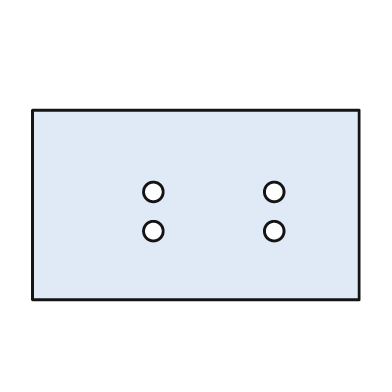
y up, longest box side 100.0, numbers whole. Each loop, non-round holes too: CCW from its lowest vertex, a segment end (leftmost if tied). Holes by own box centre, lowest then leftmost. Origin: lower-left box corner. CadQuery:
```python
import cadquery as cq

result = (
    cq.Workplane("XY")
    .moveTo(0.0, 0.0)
    .lineTo(100.0, 0.0)
    .lineTo(100.0, 58.0)
    .lineTo(0.0, 58.0)
    .close()
    .moveTo(37.0, 21.0)
    .circle(3.0)
    .moveTo(74.0, 21.0)
    .circle(3.0)
    .moveTo(37.0, 33.0)
    .circle(3.0)
    .moveTo(74.0, 33.0)
    .circle(3.0)
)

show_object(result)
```